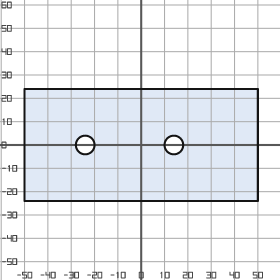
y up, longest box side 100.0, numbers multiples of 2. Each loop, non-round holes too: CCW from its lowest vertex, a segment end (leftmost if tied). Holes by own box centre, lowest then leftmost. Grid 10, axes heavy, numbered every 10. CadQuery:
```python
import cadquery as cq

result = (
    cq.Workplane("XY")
    .moveTo(-50.0, -24.0)
    .lineTo(50.0, -24.0)
    .lineTo(50.0, 24.0)
    .lineTo(-50.0, 24.0)
    .close()
    .moveTo(-24.0, 0.0)
    .circle(4.0)
    .moveTo(14.0, 0.0)
    .circle(4.0)
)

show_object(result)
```